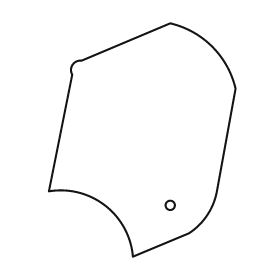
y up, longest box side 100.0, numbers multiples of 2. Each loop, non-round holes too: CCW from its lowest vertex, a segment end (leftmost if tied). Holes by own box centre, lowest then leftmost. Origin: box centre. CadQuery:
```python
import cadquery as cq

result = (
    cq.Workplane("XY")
    .moveTo(-4.0, -50.0)
    .lineTo(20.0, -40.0)
    .threePointArc((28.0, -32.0), (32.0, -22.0))
    .lineTo(40.0, 22.0)
    .threePointArc((30.0, 40.0), (12.0, 50.0))
    .lineTo(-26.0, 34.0)
    .threePointArc((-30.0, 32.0), (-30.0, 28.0))
    .lineTo(-40.0, -22.0)
    .threePointArc((-16.0, -28.0), (-4.0, -50.0))
    .close()
    .moveTo(12.0, -28.0)
    .circle(2.0)
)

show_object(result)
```